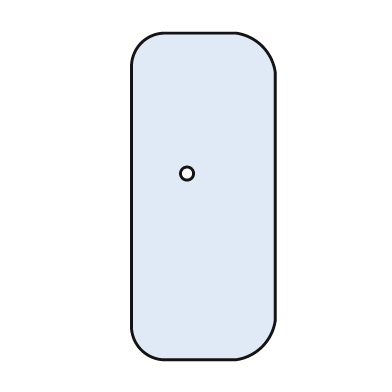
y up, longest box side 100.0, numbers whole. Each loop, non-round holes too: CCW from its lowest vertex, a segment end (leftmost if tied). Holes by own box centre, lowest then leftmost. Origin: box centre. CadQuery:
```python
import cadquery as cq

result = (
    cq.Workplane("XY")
    .moveTo(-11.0, -50.0)
    .lineTo(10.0, -50.0)
    .threePointArc((18.0, -46.0), (22.0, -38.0))
    .lineTo(22.0, 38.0)
    .threePointArc((18.0, 46.0), (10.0, 50.0))
    .lineTo(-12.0, 50.0)
    .threePointArc((-19.0, 47.0), (-22.0, 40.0))
    .lineTo(-22.0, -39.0)
    .threePointArc((-19.0, -47.0), (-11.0, -50.0))
    .close()
    .moveTo(-5.0, 7.0)
    .circle(2.0)
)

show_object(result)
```